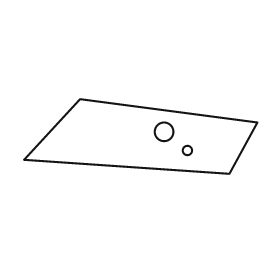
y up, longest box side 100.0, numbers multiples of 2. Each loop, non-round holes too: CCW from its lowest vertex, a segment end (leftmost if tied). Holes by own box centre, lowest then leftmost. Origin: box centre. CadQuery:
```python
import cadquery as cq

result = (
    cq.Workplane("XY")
    .moveTo(38.0, -16.0)
    .lineTo(50.0, 6.0)
    .lineTo(-26.0, 16.0)
    .lineTo(-50.0, -10.0)
    .close()
    .moveTo(20.0, -6.0)
    .circle(2.0)
    .moveTo(10.0, 2.0)
    .circle(4.0)
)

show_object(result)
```